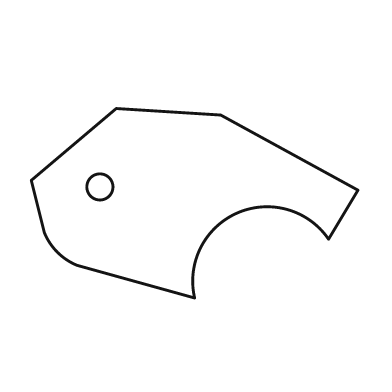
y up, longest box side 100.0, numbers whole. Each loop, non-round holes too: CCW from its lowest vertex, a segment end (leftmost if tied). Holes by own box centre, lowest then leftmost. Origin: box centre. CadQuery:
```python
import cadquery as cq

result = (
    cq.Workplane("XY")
    .moveTo(0.0, -29.0)
    .threePointArc((13.0, -3.0), (41.0, -11.0))
    .lineTo(50.0, 4.0)
    .lineTo(8.0, 27.0)
    .lineTo(-24.0, 29.0)
    .lineTo(-50.0, 7.0)
    .lineTo(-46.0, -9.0)
    .threePointArc((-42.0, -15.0), (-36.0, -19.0))
    .close()
    .moveTo(-29.0, 5.0)
    .circle(4.0)
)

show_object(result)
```